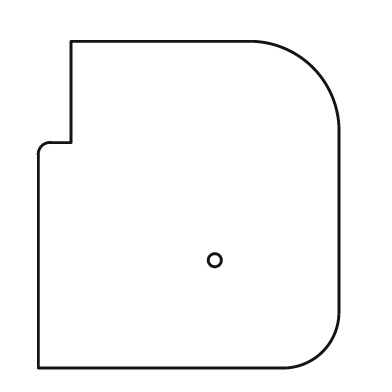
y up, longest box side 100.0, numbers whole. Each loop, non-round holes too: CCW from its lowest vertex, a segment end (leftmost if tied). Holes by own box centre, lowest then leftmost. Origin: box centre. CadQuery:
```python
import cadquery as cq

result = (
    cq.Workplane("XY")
    .moveTo(-46.0, -50.0)
    .lineTo(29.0, -50.0)
    .threePointArc((41.0, -45.0), (46.0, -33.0))
    .lineTo(46.0, 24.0)
    .threePointArc((38.0, 42.0), (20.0, 50.0))
    .lineTo(-36.0, 50.0)
    .lineTo(-36.0, 19.0)
    .lineTo(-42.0, 19.0)
    .threePointArc((-45.0, 18.0), (-46.0, 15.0))
    .close()
    .moveTo(8.0, -17.0)
    .circle(2.0)
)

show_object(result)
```